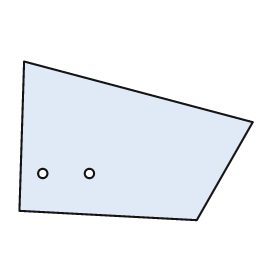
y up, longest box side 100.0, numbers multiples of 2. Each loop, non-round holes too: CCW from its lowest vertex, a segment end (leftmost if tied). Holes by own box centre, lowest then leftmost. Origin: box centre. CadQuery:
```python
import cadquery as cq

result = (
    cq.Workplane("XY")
    .moveTo(26.0, -34.0)
    .lineTo(50.0, 8.0)
    .lineTo(-48.0, 34.0)
    .lineTo(-50.0, -30.0)
    .close()
    .moveTo(-40.0, -14.0)
    .circle(2.0)
    .moveTo(-20.0, -14.0)
    .circle(2.0)
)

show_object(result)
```